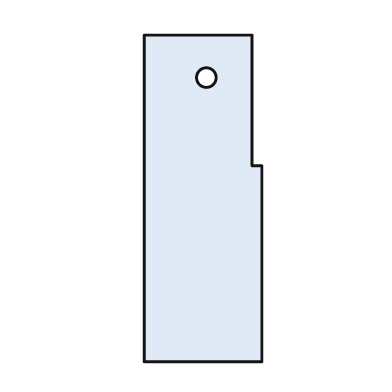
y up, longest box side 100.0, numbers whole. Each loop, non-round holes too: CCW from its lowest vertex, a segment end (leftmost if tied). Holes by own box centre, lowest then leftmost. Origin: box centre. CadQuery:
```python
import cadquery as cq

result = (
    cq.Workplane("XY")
    .moveTo(-18.0, -50.0)
    .lineTo(18.0, -50.0)
    .lineTo(18.0, 10.0)
    .lineTo(15.0, 10.0)
    .lineTo(15.0, 50.0)
    .lineTo(-18.0, 50.0)
    .close()
    .moveTo(1.0, 37.0)
    .circle(3.0)
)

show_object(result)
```